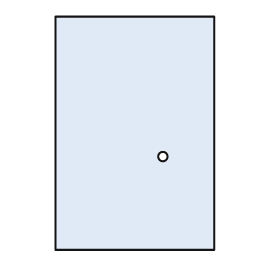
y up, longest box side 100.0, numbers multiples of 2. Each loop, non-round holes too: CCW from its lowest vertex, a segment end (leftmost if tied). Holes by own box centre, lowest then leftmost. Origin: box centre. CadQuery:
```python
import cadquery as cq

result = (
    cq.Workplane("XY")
    .moveTo(-34.0, -50.0)
    .lineTo(34.0, -50.0)
    .lineTo(34.0, 50.0)
    .lineTo(-34.0, 50.0)
    .close()
    .moveTo(12.0, -10.0)
    .circle(2.0)
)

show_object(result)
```